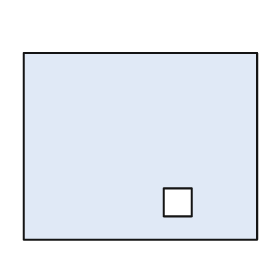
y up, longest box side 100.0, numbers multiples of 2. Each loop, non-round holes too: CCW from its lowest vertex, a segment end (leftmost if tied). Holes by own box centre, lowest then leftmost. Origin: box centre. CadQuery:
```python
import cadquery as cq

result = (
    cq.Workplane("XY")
    .moveTo(-50.0, -40.0)
    .lineTo(50.0, -40.0)
    .lineTo(50.0, 40.0)
    .lineTo(-50.0, 40.0)
    .close()
    .moveTo(10.0, -30.0)
    .lineTo(22.0, -30.0)
    .lineTo(22.0, -18.0)
    .lineTo(10.0, -18.0)
    .close()
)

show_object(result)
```